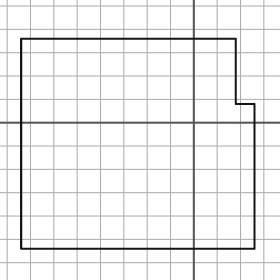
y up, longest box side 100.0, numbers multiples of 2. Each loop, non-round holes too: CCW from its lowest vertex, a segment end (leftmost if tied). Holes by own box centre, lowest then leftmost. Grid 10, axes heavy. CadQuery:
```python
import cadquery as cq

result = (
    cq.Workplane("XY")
    .moveTo(-74.0, -54.0)
    .lineTo(26.0, -54.0)
    .lineTo(26.0, 8.0)
    .lineTo(18.0, 8.0)
    .lineTo(18.0, 36.0)
    .lineTo(-74.0, 36.0)
    .close()
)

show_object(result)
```